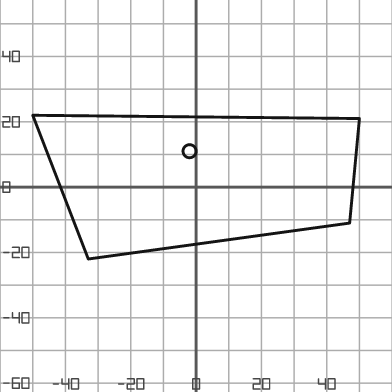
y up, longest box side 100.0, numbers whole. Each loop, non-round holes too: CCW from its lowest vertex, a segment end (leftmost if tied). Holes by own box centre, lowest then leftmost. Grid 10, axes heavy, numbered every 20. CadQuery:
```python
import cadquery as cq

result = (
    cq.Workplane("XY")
    .moveTo(-33.0, -22.0)
    .lineTo(47.0, -11.0)
    .lineTo(50.0, 21.0)
    .lineTo(-50.0, 22.0)
    .close()
    .moveTo(-2.0, 11.0)
    .circle(2.0)
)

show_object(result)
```